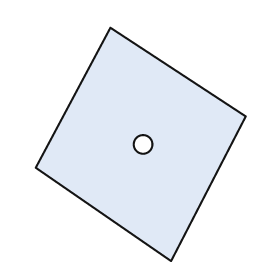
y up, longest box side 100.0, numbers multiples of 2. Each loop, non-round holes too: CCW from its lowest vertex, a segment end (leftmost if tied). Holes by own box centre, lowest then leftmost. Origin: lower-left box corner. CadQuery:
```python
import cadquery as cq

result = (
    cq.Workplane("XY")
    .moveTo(58.0, 0.0)
    .lineTo(90.0, 62.0)
    .lineTo(32.0, 100.0)
    .lineTo(0.0, 40.0)
    .close()
    .moveTo(46.0, 50.0)
    .circle(4.0)
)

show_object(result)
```